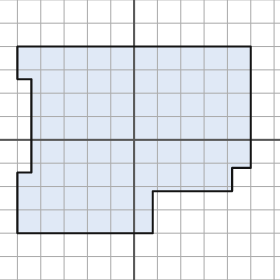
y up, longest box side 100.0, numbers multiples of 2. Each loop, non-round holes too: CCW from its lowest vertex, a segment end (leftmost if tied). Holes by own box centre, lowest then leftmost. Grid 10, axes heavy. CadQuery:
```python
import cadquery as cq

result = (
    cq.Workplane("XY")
    .moveTo(-50.0, -40.0)
    .lineTo(8.0, -40.0)
    .lineTo(8.0, -22.0)
    .lineTo(42.0, -22.0)
    .lineTo(42.0, -12.0)
    .lineTo(50.0, -12.0)
    .lineTo(50.0, 40.0)
    .lineTo(-50.0, 40.0)
    .lineTo(-50.0, 26.0)
    .lineTo(-44.0, 26.0)
    .lineTo(-44.0, -14.0)
    .lineTo(-50.0, -14.0)
    .close()
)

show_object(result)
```